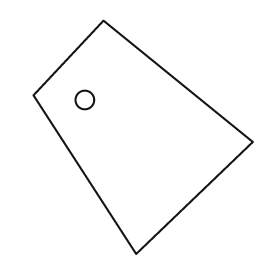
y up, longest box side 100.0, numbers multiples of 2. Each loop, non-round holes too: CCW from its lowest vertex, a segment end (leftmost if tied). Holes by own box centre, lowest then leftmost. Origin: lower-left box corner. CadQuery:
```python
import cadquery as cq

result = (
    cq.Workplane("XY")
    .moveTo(44.0, 0.0)
    .lineTo(94.0, 48.0)
    .lineTo(30.0, 100.0)
    .lineTo(0.0, 68.0)
    .close()
    .moveTo(22.0, 66.0)
    .circle(4.0)
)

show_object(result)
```